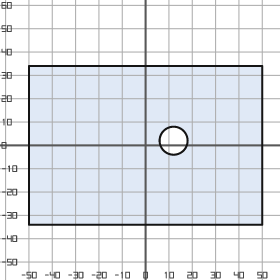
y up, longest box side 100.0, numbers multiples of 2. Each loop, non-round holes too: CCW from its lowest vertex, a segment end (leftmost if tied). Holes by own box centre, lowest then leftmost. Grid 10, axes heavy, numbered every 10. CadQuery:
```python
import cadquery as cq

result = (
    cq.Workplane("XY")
    .moveTo(-50.0, -34.0)
    .lineTo(50.0, -34.0)
    .lineTo(50.0, 34.0)
    .lineTo(-50.0, 34.0)
    .close()
    .moveTo(12.0, 2.0)
    .circle(6.0)
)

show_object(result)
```